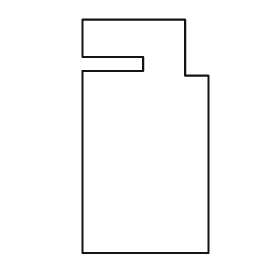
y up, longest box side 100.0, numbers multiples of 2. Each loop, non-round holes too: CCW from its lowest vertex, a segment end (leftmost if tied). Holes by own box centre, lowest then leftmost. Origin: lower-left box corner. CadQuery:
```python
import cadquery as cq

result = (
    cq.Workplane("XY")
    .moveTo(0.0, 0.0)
    .lineTo(54.0, 0.0)
    .lineTo(54.0, 76.0)
    .lineTo(44.0, 76.0)
    .lineTo(44.0, 100.0)
    .lineTo(0.0, 100.0)
    .lineTo(0.0, 84.0)
    .lineTo(26.0, 84.0)
    .lineTo(26.0, 78.0)
    .lineTo(0.0, 78.0)
    .close()
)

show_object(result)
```